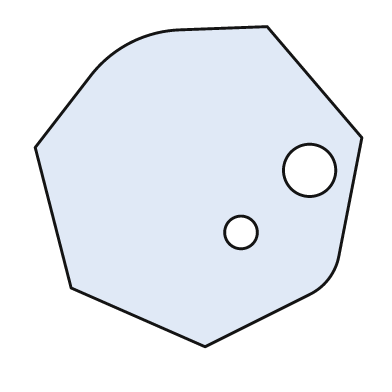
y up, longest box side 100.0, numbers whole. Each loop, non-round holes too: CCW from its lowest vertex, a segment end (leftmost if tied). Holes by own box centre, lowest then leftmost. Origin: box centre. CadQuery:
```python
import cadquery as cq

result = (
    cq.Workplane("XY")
    .moveTo(2.0, -49.0)
    .lineTo(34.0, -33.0)
    .threePointArc((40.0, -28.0), (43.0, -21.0))
    .lineTo(50.0, 15.0)
    .lineTo(21.0, 49.0)
    .lineTo(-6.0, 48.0)
    .threePointArc((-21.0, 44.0), (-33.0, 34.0))
    .lineTo(-50.0, 12.0)
    .lineTo(-39.0, -31.0)
    .close()
    .moveTo(13.0, -14.0)
    .circle(5.0)
    .moveTo(34.0, 5.0)
    .circle(8.0)
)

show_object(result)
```